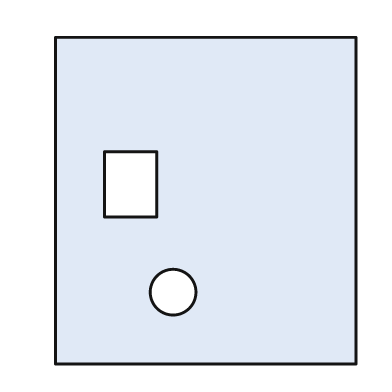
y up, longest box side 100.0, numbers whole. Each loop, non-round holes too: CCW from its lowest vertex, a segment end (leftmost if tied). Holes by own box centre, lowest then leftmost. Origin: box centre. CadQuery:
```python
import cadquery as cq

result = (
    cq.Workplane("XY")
    .moveTo(-46.0, -50.0)
    .lineTo(46.0, -50.0)
    .lineTo(46.0, 50.0)
    .lineTo(-46.0, 50.0)
    .close()
    .moveTo(-10.0, -28.0)
    .circle(7.0)
    .moveTo(-31.0, -5.0)
    .lineTo(-15.0, -5.0)
    .lineTo(-15.0, 15.0)
    .lineTo(-31.0, 15.0)
    .close()
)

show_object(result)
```